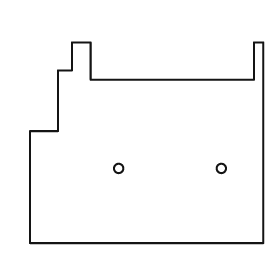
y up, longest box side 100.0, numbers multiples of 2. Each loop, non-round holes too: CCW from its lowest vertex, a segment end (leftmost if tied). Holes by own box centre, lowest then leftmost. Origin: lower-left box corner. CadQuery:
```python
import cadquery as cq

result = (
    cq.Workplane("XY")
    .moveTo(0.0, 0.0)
    .lineTo(100.0, 0.0)
    .lineTo(100.0, 86.0)
    .lineTo(96.0, 86.0)
    .lineTo(96.0, 70.0)
    .lineTo(26.0, 70.0)
    .lineTo(26.0, 86.0)
    .lineTo(18.0, 86.0)
    .lineTo(18.0, 74.0)
    .lineTo(12.0, 74.0)
    .lineTo(12.0, 48.0)
    .lineTo(0.0, 48.0)
    .close()
    .moveTo(38.0, 32.0)
    .circle(2.0)
    .moveTo(82.0, 32.0)
    .circle(2.0)
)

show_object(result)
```